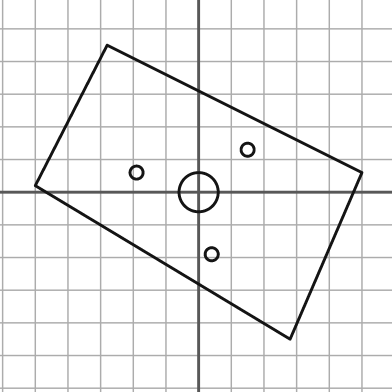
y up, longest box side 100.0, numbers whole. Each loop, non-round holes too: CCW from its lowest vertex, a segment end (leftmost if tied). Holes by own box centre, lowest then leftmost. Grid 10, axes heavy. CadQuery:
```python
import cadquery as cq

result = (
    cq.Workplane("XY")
    .moveTo(28.0, -45.0)
    .lineTo(50.0, 6.0)
    .lineTo(-28.0, 45.0)
    .lineTo(-50.0, 2.0)
    .close()
    .moveTo(4.0, -19.0)
    .circle(2.0)
    .moveTo(0.0, 0.0)
    .circle(6.0)
    .moveTo(-19.0, 6.0)
    .circle(2.0)
    .moveTo(15.0, 13.0)
    .circle(2.0)
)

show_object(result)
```